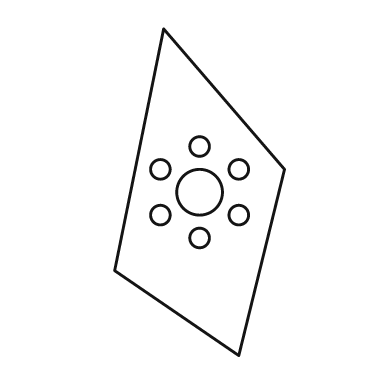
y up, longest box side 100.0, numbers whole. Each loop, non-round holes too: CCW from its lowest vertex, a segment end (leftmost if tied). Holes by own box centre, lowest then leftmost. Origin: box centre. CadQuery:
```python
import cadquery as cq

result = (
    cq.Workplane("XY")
    .moveTo(12.0, -50.0)
    .lineTo(26.0, 7.0)
    .lineTo(-11.0, 50.0)
    .lineTo(-26.0, -24.0)
    .close()
    .moveTo(0.0, -14.0)
    .circle(3.0)
    .moveTo(-12.0, -7.0)
    .circle(3.0)
    .moveTo(12.0, -7.0)
    .circle(3.0)
    .moveTo(0.0, 0.0)
    .circle(7.0)
    .moveTo(-12.0, 7.0)
    .circle(3.0)
    .moveTo(12.0, 7.0)
    .circle(3.0)
    .moveTo(0.0, 14.0)
    .circle(3.0)
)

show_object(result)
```